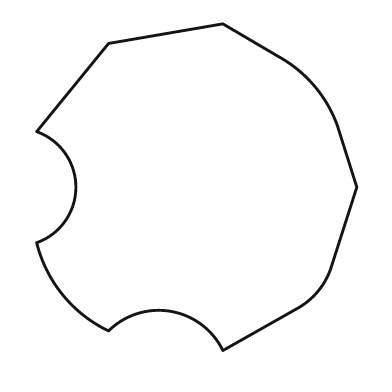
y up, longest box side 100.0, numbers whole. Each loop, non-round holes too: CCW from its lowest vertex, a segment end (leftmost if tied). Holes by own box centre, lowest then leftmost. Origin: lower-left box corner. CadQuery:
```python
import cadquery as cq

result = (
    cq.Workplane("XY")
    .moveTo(57.0, 0.0)
    .lineTo(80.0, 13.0)
    .threePointArc((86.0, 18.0), (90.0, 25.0))
    .lineTo(98.0, 50.0)
    .lineTo(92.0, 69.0)
    .threePointArc((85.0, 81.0), (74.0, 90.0))
    .lineTo(57.0, 100.0)
    .lineTo(22.0, 94.0)
    .lineTo(0.0, 67.0)
    .threePointArc((12.0, 50.0), (0.0, 33.0))
    .threePointArc((8.0, 17.0), (22.0, 6.0))
    .threePointArc((41.0, 12.0), (57.0, 0.0))
    .close()
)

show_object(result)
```